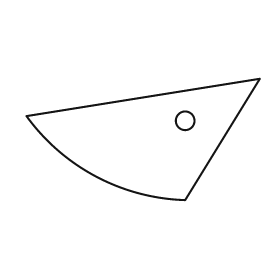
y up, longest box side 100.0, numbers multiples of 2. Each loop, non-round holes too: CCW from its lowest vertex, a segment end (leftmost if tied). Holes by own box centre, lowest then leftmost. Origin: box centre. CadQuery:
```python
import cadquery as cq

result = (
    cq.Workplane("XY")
    .moveTo(18.0, -26.0)
    .lineTo(50.0, 26.0)
    .lineTo(-50.0, 10.0)
    .threePointArc((-20.0, -16.0), (18.0, -26.0))
    .close()
    .moveTo(18.0, 8.0)
    .circle(4.0)
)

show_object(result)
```